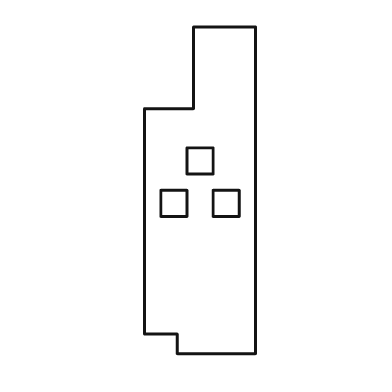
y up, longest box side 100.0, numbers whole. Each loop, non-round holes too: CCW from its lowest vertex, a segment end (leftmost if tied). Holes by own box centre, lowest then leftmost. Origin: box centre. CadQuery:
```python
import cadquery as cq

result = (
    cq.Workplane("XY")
    .moveTo(-7.0, -50.0)
    .lineTo(17.0, -50.0)
    .lineTo(17.0, 50.0)
    .lineTo(-2.0, 50.0)
    .lineTo(-2.0, 25.0)
    .lineTo(-17.0, 25.0)
    .lineTo(-17.0, -44.0)
    .lineTo(-7.0, -44.0)
    .close()
    .moveTo(-12.0, -8.0)
    .lineTo(-4.0, -8.0)
    .lineTo(-4.0, 0.0)
    .lineTo(-12.0, 0.0)
    .close()
    .moveTo(4.0, -8.0)
    .lineTo(12.0, -8.0)
    .lineTo(12.0, 0.0)
    .lineTo(4.0, 0.0)
    .close()
    .moveTo(-4.0, 5.0)
    .lineTo(4.0, 5.0)
    .lineTo(4.0, 13.0)
    .lineTo(-4.0, 13.0)
    .close()
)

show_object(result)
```